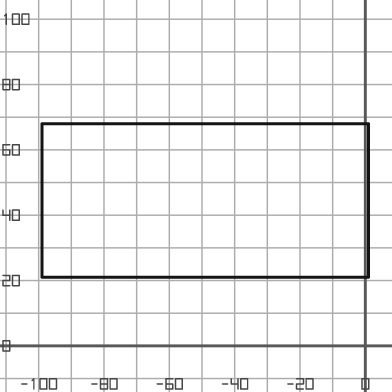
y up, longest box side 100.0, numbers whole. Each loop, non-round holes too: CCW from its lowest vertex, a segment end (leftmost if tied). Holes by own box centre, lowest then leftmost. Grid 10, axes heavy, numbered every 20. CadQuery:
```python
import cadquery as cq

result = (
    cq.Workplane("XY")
    .moveTo(-99.0, 21.0)
    .lineTo(1.0, 21.0)
    .lineTo(1.0, 68.0)
    .lineTo(-99.0, 68.0)
    .close()
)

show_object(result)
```